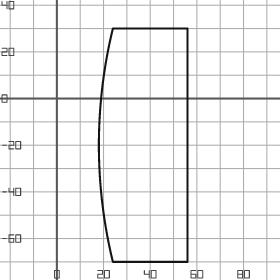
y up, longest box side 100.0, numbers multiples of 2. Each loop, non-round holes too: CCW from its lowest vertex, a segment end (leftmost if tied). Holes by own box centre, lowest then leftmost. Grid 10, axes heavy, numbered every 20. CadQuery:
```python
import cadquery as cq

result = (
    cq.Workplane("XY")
    .moveTo(24.0, -70.0)
    .lineTo(56.0, -70.0)
    .lineTo(56.0, 30.0)
    .lineTo(24.0, 30.0)
    .threePointArc((18.0, -20.0), (24.0, -70.0))
    .close()
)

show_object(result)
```